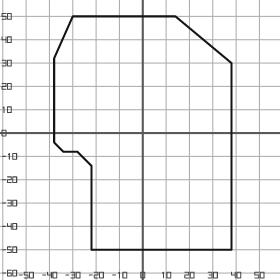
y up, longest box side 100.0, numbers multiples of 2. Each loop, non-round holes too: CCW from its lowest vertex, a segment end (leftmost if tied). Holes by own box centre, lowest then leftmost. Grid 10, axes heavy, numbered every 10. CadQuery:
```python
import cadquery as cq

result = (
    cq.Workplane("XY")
    .moveTo(-22.0, -50.0)
    .lineTo(38.0, -50.0)
    .lineTo(38.0, 30.0)
    .lineTo(14.0, 50.0)
    .lineTo(-30.0, 50.0)
    .lineTo(-38.0, 32.0)
    .lineTo(-38.0, -4.0)
    .lineTo(-34.0, -8.0)
    .lineTo(-28.0, -8.0)
    .lineTo(-22.0, -14.0)
    .close()
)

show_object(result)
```